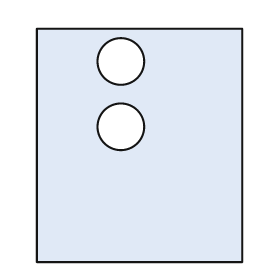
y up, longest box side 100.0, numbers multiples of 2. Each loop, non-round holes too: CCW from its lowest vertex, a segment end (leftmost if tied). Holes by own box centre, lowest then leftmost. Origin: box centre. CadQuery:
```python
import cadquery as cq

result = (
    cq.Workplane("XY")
    .moveTo(-44.0, -50.0)
    .lineTo(44.0, -50.0)
    .lineTo(44.0, 50.0)
    .lineTo(-44.0, 50.0)
    .close()
    .moveTo(-8.0, 8.0)
    .circle(10.0)
    .moveTo(-8.0, 36.0)
    .circle(10.0)
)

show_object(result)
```